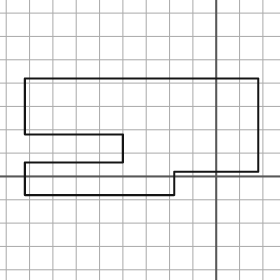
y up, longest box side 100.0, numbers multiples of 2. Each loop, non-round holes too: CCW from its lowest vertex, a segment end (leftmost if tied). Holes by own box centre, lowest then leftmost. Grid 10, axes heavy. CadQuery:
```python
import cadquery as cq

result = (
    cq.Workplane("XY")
    .moveTo(-82.0, -8.0)
    .lineTo(-18.0, -8.0)
    .lineTo(-18.0, 2.0)
    .lineTo(18.0, 2.0)
    .lineTo(18.0, 42.0)
    .lineTo(-82.0, 42.0)
    .lineTo(-82.0, 18.0)
    .lineTo(-40.0, 18.0)
    .lineTo(-40.0, 6.0)
    .lineTo(-82.0, 6.0)
    .close()
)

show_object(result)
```